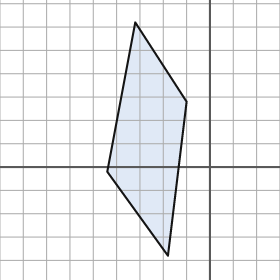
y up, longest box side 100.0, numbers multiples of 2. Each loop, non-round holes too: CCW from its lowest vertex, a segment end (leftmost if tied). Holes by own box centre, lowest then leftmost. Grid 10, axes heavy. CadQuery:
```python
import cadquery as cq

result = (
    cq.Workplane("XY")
    .moveTo(-18.0, -38.0)
    .lineTo(-10.0, 28.0)
    .lineTo(-32.0, 62.0)
    .lineTo(-44.0, -2.0)
    .close()
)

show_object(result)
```